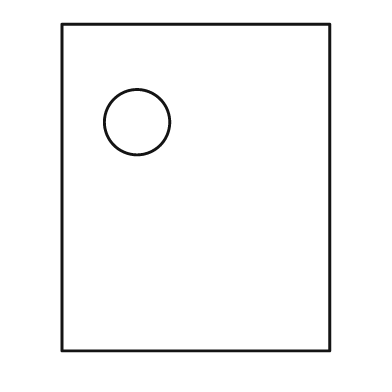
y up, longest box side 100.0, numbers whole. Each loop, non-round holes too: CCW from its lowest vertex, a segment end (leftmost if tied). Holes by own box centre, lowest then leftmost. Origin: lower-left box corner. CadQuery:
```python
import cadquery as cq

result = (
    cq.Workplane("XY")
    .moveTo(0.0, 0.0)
    .lineTo(82.0, 0.0)
    .lineTo(82.0, 100.0)
    .lineTo(0.0, 100.0)
    .close()
    .moveTo(23.0, 70.0)
    .circle(10.0)
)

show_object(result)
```